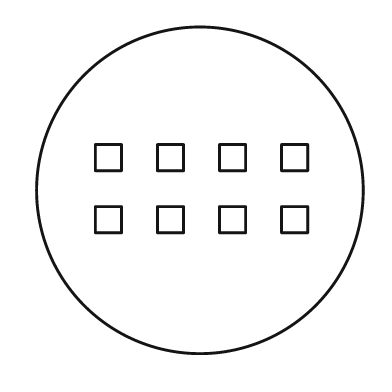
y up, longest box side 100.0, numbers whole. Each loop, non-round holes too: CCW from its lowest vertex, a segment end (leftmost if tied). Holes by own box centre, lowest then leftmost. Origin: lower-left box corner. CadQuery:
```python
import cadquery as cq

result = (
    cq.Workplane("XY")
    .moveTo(50.0, 50.0)
    .circle(50.0)
    .moveTo(18.0, 37.0)
    .lineTo(26.0, 37.0)
    .lineTo(26.0, 45.0)
    .lineTo(18.0, 45.0)
    .close()
    .moveTo(37.0, 37.0)
    .lineTo(45.0, 37.0)
    .lineTo(45.0, 45.0)
    .lineTo(37.0, 45.0)
    .close()
    .moveTo(56.0, 37.0)
    .lineTo(64.0, 37.0)
    .lineTo(64.0, 45.0)
    .lineTo(56.0, 45.0)
    .close()
    .moveTo(75.0, 37.0)
    .lineTo(83.0, 37.0)
    .lineTo(83.0, 45.0)
    .lineTo(75.0, 45.0)
    .close()
    .moveTo(18.0, 56.0)
    .lineTo(26.0, 56.0)
    .lineTo(26.0, 64.0)
    .lineTo(18.0, 64.0)
    .close()
    .moveTo(37.0, 56.0)
    .lineTo(45.0, 56.0)
    .lineTo(45.0, 64.0)
    .lineTo(37.0, 64.0)
    .close()
    .moveTo(56.0, 56.0)
    .lineTo(64.0, 56.0)
    .lineTo(64.0, 64.0)
    .lineTo(56.0, 64.0)
    .close()
    .moveTo(75.0, 56.0)
    .lineTo(83.0, 56.0)
    .lineTo(83.0, 64.0)
    .lineTo(75.0, 64.0)
    .close()
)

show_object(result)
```